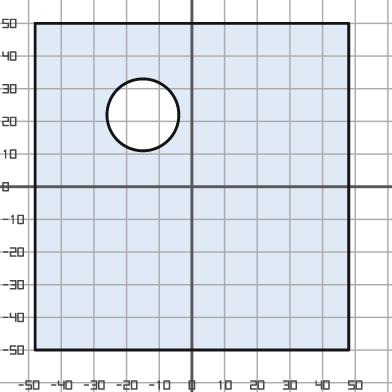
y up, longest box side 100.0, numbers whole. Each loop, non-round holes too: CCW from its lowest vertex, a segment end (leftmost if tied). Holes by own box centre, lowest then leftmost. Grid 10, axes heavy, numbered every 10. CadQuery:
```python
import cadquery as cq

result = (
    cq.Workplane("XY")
    .moveTo(-48.0, -50.0)
    .lineTo(48.0, -50.0)
    .lineTo(48.0, 50.0)
    .lineTo(-48.0, 50.0)
    .close()
    .moveTo(-15.0, 22.0)
    .circle(11.0)
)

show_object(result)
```